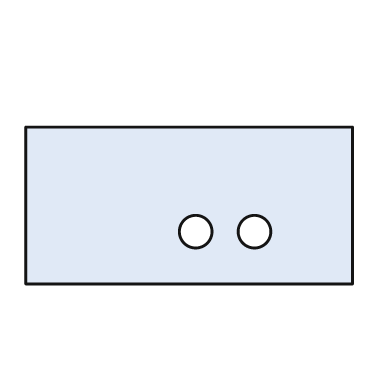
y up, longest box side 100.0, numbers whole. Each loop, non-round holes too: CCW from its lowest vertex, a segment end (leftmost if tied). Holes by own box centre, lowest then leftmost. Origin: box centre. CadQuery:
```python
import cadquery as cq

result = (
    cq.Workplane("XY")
    .moveTo(-50.0, -24.0)
    .lineTo(50.0, -24.0)
    .lineTo(50.0, 24.0)
    .lineTo(-50.0, 24.0)
    .close()
    .moveTo(2.0, -8.0)
    .circle(5.0)
    .moveTo(20.0, -8.0)
    .circle(5.0)
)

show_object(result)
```